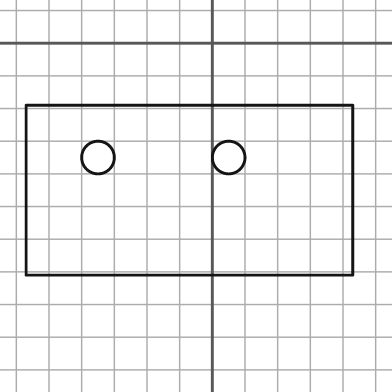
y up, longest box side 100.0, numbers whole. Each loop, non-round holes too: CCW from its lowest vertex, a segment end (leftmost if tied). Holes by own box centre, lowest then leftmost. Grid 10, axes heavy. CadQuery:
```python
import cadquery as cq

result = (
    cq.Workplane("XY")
    .moveTo(-57.0, -71.0)
    .lineTo(43.0, -71.0)
    .lineTo(43.0, -19.0)
    .lineTo(-57.0, -19.0)
    .close()
    .moveTo(-35.0, -35.0)
    .circle(5.0)
    .moveTo(5.0, -35.0)
    .circle(5.0)
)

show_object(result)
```